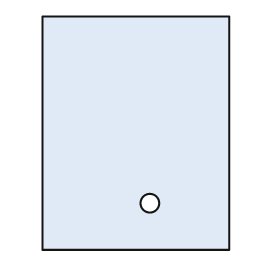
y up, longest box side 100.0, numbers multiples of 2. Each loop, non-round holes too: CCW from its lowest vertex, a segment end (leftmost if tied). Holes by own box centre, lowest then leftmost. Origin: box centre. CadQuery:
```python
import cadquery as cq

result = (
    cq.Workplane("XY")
    .moveTo(-40.0, -50.0)
    .lineTo(40.0, -50.0)
    .lineTo(40.0, 50.0)
    .lineTo(-40.0, 50.0)
    .close()
    .moveTo(6.0, -30.0)
    .circle(4.0)
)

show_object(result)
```